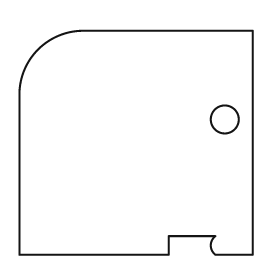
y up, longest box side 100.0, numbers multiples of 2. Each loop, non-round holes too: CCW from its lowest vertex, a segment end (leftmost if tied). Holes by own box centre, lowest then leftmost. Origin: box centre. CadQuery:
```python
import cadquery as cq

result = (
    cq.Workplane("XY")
    .moveTo(-50.0, -48.0)
    .lineTo(14.0, -48.0)
    .lineTo(14.0, -40.0)
    .lineTo(34.0, -40.0)
    .threePointArc((32.0, -44.0), (34.0, -48.0))
    .lineTo(50.0, -48.0)
    .lineTo(50.0, 48.0)
    .lineTo(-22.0, 48.0)
    .threePointArc((-42.0, 40.0), (-50.0, 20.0))
    .close()
    .moveTo(38.0, 10.0)
    .circle(6.0)
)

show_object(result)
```